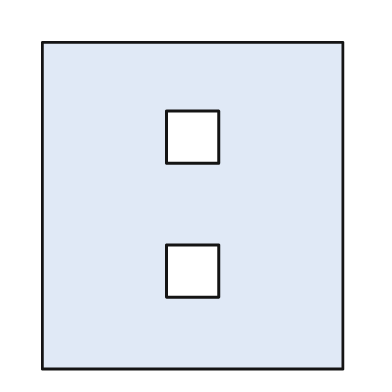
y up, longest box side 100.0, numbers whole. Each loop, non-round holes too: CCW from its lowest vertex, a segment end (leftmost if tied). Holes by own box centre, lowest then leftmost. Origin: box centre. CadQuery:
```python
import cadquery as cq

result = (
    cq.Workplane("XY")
    .moveTo(-46.0, -50.0)
    .lineTo(46.0, -50.0)
    .lineTo(46.0, 50.0)
    .lineTo(-46.0, 50.0)
    .close()
    .moveTo(-8.0, -28.0)
    .lineTo(8.0, -28.0)
    .lineTo(8.0, -12.0)
    .lineTo(-8.0, -12.0)
    .close()
    .moveTo(-8.0, 13.0)
    .lineTo(8.0, 13.0)
    .lineTo(8.0, 29.0)
    .lineTo(-8.0, 29.0)
    .close()
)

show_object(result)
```